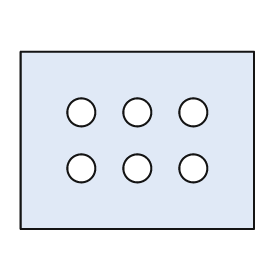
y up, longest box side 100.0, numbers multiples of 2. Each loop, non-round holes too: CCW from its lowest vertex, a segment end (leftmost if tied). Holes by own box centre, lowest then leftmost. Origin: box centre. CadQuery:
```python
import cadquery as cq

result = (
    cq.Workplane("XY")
    .moveTo(-50.0, -38.0)
    .lineTo(50.0, -38.0)
    .lineTo(50.0, 38.0)
    .lineTo(-50.0, 38.0)
    .close()
    .moveTo(-24.0, -12.0)
    .circle(6.0)
    .moveTo(0.0, -12.0)
    .circle(6.0)
    .moveTo(24.0, -12.0)
    .circle(6.0)
    .moveTo(-24.0, 12.0)
    .circle(6.0)
    .moveTo(0.0, 12.0)
    .circle(6.0)
    .moveTo(24.0, 12.0)
    .circle(6.0)
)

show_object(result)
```